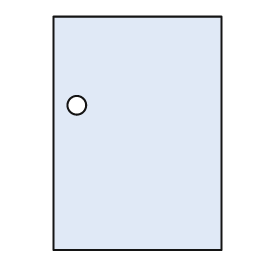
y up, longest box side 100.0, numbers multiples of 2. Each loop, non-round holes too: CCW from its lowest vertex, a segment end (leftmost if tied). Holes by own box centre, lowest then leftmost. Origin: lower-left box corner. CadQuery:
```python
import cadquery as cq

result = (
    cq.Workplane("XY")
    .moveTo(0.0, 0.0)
    .lineTo(72.0, 0.0)
    .lineTo(72.0, 100.0)
    .lineTo(0.0, 100.0)
    .close()
    .moveTo(10.0, 62.0)
    .circle(4.0)
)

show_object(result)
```